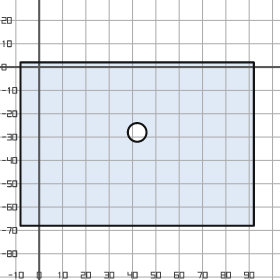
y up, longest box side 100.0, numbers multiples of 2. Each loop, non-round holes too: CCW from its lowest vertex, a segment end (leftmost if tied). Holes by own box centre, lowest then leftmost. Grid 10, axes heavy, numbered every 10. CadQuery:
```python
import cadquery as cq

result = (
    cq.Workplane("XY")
    .moveTo(-8.0, -68.0)
    .lineTo(92.0, -68.0)
    .lineTo(92.0, 2.0)
    .lineTo(-8.0, 2.0)
    .close()
    .moveTo(42.0, -28.0)
    .circle(4.0)
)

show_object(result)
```